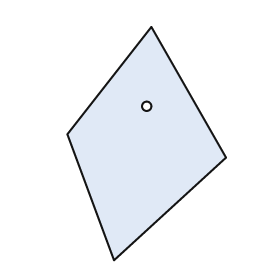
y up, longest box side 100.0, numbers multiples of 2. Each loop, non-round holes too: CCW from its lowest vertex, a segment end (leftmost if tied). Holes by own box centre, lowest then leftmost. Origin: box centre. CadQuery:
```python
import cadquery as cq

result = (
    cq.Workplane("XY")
    .moveTo(-14.0, -50.0)
    .lineTo(34.0, -6.0)
    .lineTo(2.0, 50.0)
    .lineTo(-34.0, 4.0)
    .close()
    .moveTo(0.0, 16.0)
    .circle(2.0)
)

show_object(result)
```